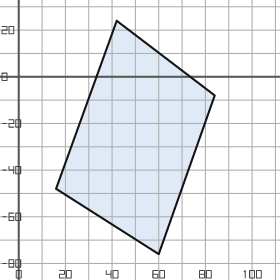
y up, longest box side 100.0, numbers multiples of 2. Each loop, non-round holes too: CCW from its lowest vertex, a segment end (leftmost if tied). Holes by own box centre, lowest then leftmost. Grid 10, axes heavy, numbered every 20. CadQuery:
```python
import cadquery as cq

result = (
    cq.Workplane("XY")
    .moveTo(60.0, -76.0)
    .lineTo(84.0, -8.0)
    .lineTo(42.0, 24.0)
    .lineTo(16.0, -48.0)
    .close()
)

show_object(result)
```